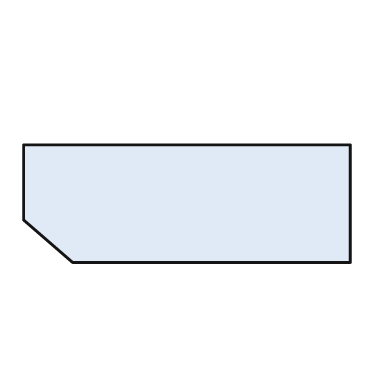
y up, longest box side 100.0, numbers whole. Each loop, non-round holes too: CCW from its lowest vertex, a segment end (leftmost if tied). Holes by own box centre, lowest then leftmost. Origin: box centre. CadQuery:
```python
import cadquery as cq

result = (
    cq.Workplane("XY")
    .moveTo(-35.0, -18.0)
    .lineTo(50.0, -18.0)
    .lineTo(50.0, 18.0)
    .lineTo(-50.0, 18.0)
    .lineTo(-50.0, -5.0)
    .close()
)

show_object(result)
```